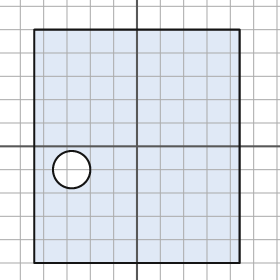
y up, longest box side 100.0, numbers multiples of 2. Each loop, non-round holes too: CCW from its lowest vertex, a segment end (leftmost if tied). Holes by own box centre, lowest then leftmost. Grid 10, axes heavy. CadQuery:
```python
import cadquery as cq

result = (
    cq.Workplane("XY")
    .moveTo(-44.0, -50.0)
    .lineTo(44.0, -50.0)
    .lineTo(44.0, 50.0)
    .lineTo(-44.0, 50.0)
    .close()
    .moveTo(-28.0, -10.0)
    .circle(8.0)
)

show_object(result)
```